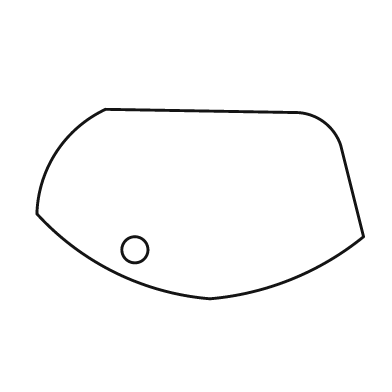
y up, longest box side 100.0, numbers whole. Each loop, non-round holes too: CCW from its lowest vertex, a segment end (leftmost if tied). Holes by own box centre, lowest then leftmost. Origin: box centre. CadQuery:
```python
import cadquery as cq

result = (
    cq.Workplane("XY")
    .moveTo(3.0, -29.0)
    .threePointArc((28.0, -23.0), (50.0, -10.0))
    .lineTo(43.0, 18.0)
    .threePointArc((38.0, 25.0), (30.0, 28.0))
    .lineTo(-29.0, 29.0)
    .threePointArc((-44.0, 16.0), (-50.0, -3.0))
    .threePointArc((-26.0, -21.0), (3.0, -29.0))
    .close()
    .moveTo(-20.0, -14.0)
    .circle(4.0)
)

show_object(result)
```